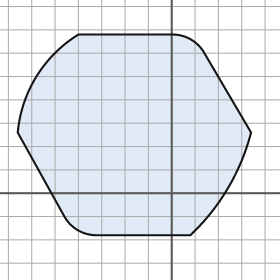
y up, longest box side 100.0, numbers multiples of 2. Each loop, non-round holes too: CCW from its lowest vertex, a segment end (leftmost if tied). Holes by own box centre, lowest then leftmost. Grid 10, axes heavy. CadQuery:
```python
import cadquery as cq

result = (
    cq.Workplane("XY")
    .moveTo(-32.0, -18.0)
    .lineTo(8.0, -18.0)
    .threePointArc((24.0, 2.0), (34.0, 26.0))
    .lineTo(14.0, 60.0)
    .threePointArc((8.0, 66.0), (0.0, 68.0))
    .lineTo(-40.0, 68.0)
    .threePointArc((-58.0, 50.0), (-66.0, 26.0))
    .lineTo(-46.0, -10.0)
    .threePointArc((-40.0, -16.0), (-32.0, -18.0))
    .close()
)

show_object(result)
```